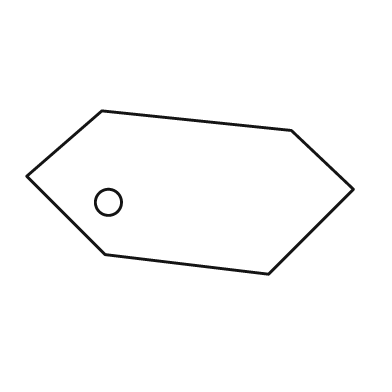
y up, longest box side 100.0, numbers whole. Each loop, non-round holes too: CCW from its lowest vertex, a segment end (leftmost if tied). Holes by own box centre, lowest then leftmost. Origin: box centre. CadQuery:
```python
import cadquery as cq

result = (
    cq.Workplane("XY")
    .moveTo(24.0, -25.0)
    .lineTo(50.0, 1.0)
    .lineTo(31.0, 19.0)
    .lineTo(-27.0, 25.0)
    .lineTo(-50.0, 5.0)
    .lineTo(-26.0, -19.0)
    .close()
    .moveTo(-25.0, -3.0)
    .circle(4.0)
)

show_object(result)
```